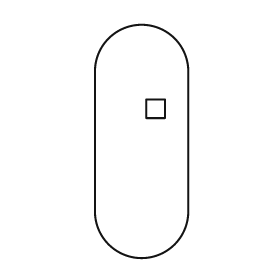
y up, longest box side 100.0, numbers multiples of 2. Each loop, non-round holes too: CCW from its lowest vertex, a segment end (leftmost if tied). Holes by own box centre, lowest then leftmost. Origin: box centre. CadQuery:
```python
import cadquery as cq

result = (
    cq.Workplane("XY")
    .moveTo(-20.0, -30.0)
    .threePointArc((0.0, -50.0), (20.0, -30.0))
    .lineTo(20.0, 30.0)
    .threePointArc((0.0, 50.0), (-20.0, 30.0))
    .close()
    .moveTo(2.0, 10.0)
    .lineTo(10.0, 10.0)
    .lineTo(10.0, 18.0)
    .lineTo(2.0, 18.0)
    .close()
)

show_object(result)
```